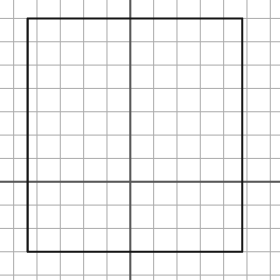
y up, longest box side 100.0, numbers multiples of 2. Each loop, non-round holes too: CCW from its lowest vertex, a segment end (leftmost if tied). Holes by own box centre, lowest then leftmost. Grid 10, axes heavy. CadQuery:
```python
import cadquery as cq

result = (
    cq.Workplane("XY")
    .moveTo(-44.0, -30.0)
    .lineTo(48.0, -30.0)
    .lineTo(48.0, 70.0)
    .lineTo(-44.0, 70.0)
    .close()
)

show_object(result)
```